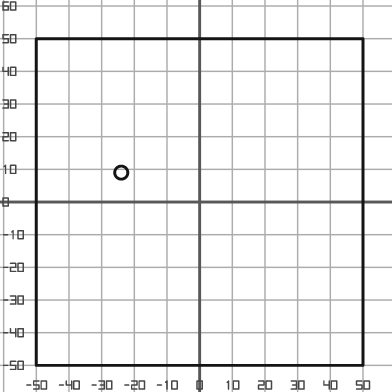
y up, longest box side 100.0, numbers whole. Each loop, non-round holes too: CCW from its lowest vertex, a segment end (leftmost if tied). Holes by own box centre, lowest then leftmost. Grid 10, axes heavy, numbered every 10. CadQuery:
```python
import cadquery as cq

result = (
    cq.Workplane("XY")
    .moveTo(-50.0, -50.0)
    .lineTo(50.0, -50.0)
    .lineTo(50.0, 50.0)
    .lineTo(-50.0, 50.0)
    .close()
    .moveTo(-24.0, 9.0)
    .circle(2.0)
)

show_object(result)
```